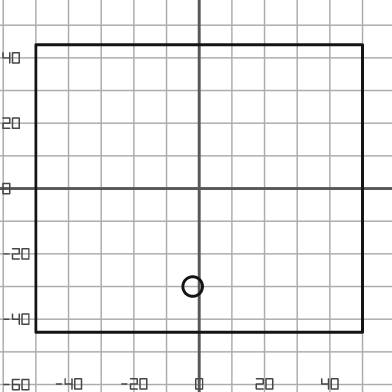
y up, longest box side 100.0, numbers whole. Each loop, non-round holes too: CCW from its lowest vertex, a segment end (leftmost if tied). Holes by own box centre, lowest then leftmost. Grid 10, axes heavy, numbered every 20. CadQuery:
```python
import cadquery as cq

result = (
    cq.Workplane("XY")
    .moveTo(-50.0, -44.0)
    .lineTo(50.0, -44.0)
    .lineTo(50.0, 44.0)
    .lineTo(-50.0, 44.0)
    .close()
    .moveTo(-2.0, -30.0)
    .circle(3.0)
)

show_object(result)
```